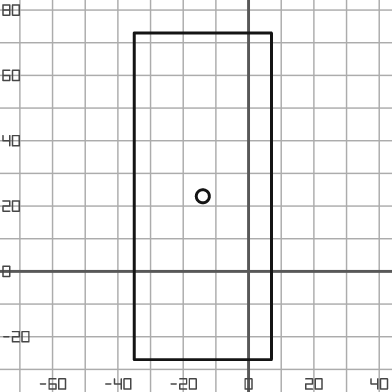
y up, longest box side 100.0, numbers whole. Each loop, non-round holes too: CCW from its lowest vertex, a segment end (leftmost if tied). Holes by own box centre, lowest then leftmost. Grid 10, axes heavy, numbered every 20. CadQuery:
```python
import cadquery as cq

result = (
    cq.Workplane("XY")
    .moveTo(-35.0, -27.0)
    .lineTo(7.0, -27.0)
    .lineTo(7.0, 73.0)
    .lineTo(-35.0, 73.0)
    .close()
    .moveTo(-14.0, 23.0)
    .circle(2.0)
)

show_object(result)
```